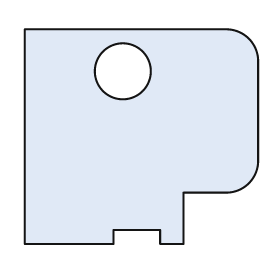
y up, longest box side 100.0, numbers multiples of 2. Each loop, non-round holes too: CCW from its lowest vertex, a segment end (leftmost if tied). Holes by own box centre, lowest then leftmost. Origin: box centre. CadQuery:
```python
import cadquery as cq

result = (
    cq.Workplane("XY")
    .moveTo(-50.0, -46.0)
    .lineTo(-12.0, -46.0)
    .lineTo(-12.0, -40.0)
    .lineTo(8.0, -40.0)
    .lineTo(8.0, -46.0)
    .lineTo(18.0, -46.0)
    .lineTo(18.0, -24.0)
    .lineTo(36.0, -24.0)
    .threePointArc((46.0, -20.0), (50.0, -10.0))
    .lineTo(50.0, 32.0)
    .threePointArc((46.0, 42.0), (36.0, 46.0))
    .lineTo(-50.0, 46.0)
    .close()
    .moveTo(-8.0, 28.0)
    .circle(12.0)
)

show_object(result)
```